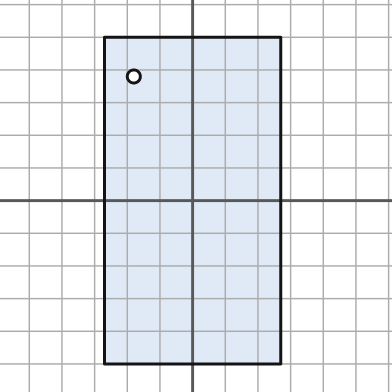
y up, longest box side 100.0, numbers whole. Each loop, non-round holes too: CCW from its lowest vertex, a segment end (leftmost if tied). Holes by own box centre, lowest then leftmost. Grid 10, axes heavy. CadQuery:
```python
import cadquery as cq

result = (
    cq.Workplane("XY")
    .moveTo(-27.0, -50.0)
    .lineTo(27.0, -50.0)
    .lineTo(27.0, 50.0)
    .lineTo(-27.0, 50.0)
    .close()
    .moveTo(-18.0, 38.0)
    .circle(2.0)
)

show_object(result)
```